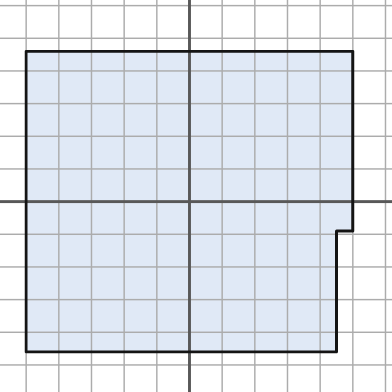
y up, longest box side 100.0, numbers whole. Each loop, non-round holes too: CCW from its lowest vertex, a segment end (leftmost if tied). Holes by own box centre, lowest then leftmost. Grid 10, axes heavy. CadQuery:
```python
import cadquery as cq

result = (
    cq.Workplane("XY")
    .moveTo(-50.0, -46.0)
    .lineTo(45.0, -46.0)
    .lineTo(45.0, -9.0)
    .lineTo(50.0, -9.0)
    .lineTo(50.0, 46.0)
    .lineTo(-50.0, 46.0)
    .close()
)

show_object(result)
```